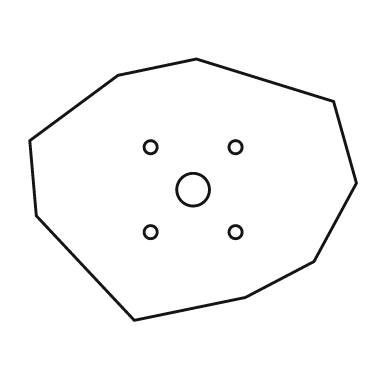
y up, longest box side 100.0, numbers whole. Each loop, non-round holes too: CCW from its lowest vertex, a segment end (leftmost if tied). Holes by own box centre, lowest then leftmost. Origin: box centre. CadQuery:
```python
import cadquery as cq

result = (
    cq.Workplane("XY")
    .moveTo(-18.0, -40.0)
    .lineTo(16.0, -33.0)
    .lineTo(37.0, -22.0)
    .lineTo(50.0, 2.0)
    .lineTo(43.0, 27.0)
    .lineTo(1.0, 40.0)
    .lineTo(-23.0, 35.0)
    .lineTo(-50.0, 15.0)
    .lineTo(-48.0, -8.0)
    .close()
    .moveTo(-13.0, -13.0)
    .circle(2.0)
    .moveTo(13.0, -13.0)
    .circle(2.0)
    .moveTo(0.0, 0.0)
    .circle(5.0)
    .moveTo(-13.0, 13.0)
    .circle(2.0)
    .moveTo(13.0, 13.0)
    .circle(2.0)
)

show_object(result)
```